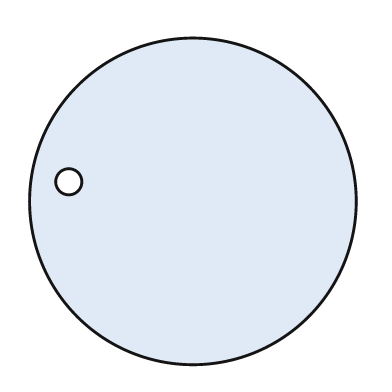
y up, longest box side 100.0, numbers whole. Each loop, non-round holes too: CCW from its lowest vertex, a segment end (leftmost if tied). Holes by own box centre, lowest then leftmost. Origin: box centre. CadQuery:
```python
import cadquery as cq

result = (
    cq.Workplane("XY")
    .moveTo(0.0, 0.0)
    .circle(50.0)
    .moveTo(-38.0, 6.0)
    .circle(4.0)
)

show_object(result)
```